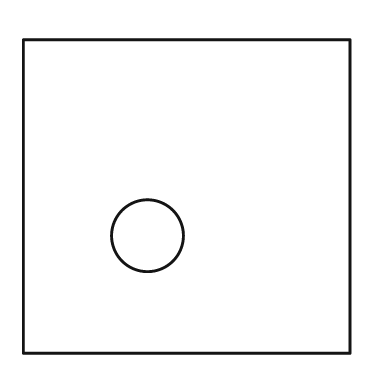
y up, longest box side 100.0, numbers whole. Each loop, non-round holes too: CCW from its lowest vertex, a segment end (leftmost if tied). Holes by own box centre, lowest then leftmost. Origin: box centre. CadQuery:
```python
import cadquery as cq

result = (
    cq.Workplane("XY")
    .moveTo(-50.0, -48.0)
    .lineTo(50.0, -48.0)
    .lineTo(50.0, 48.0)
    .lineTo(-50.0, 48.0)
    .close()
    .moveTo(-12.0, -12.0)
    .circle(11.0)
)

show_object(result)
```